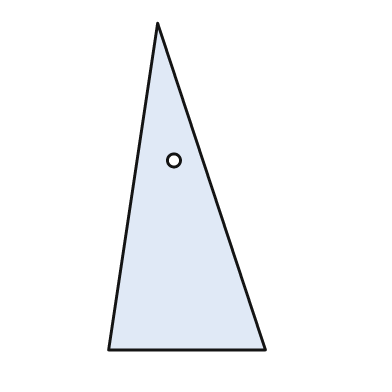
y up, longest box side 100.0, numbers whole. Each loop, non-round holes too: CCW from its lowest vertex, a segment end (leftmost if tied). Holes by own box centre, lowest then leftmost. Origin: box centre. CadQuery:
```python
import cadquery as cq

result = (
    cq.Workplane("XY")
    .moveTo(-24.0, -50.0)
    .lineTo(24.0, -50.0)
    .lineTo(-9.0, 50.0)
    .close()
    .moveTo(-4.0, 8.0)
    .circle(2.0)
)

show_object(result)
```